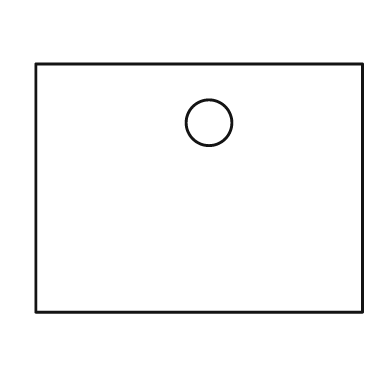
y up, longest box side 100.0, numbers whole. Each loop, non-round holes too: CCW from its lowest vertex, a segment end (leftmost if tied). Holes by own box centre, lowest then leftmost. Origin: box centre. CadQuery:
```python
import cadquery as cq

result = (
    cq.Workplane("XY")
    .moveTo(-50.0, -38.0)
    .lineTo(50.0, -38.0)
    .lineTo(50.0, 38.0)
    .lineTo(-50.0, 38.0)
    .close()
    .moveTo(3.0, 20.0)
    .circle(7.0)
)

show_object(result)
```